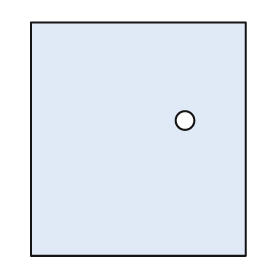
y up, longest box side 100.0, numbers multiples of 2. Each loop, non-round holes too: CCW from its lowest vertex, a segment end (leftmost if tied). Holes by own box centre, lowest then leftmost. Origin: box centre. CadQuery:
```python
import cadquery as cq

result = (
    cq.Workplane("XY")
    .moveTo(-46.0, -50.0)
    .lineTo(46.0, -50.0)
    .lineTo(46.0, 50.0)
    .lineTo(-46.0, 50.0)
    .close()
    .moveTo(20.0, 8.0)
    .circle(4.0)
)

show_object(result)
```